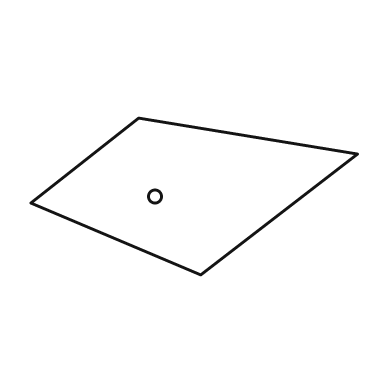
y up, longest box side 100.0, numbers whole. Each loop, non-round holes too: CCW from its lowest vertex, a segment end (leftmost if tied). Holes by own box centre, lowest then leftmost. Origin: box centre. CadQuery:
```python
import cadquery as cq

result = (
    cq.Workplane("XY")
    .moveTo(2.0, -24.0)
    .lineTo(50.0, 13.0)
    .lineTo(-17.0, 24.0)
    .lineTo(-50.0, -2.0)
    .close()
    .moveTo(-12.0, 0.0)
    .circle(2.0)
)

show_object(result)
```